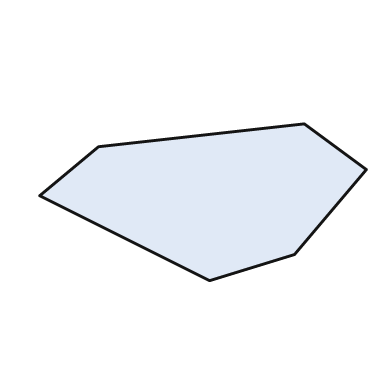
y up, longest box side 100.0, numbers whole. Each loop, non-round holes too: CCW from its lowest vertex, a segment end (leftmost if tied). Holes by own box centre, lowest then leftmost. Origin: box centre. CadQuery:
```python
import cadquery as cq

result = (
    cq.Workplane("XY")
    .moveTo(2.0, -24.0)
    .lineTo(28.0, -16.0)
    .lineTo(50.0, 10.0)
    .lineTo(31.0, 24.0)
    .lineTo(-32.0, 17.0)
    .lineTo(-50.0, 2.0)
    .close()
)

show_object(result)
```